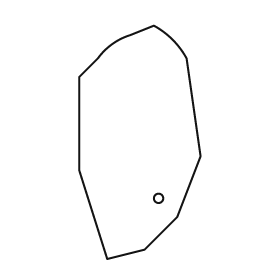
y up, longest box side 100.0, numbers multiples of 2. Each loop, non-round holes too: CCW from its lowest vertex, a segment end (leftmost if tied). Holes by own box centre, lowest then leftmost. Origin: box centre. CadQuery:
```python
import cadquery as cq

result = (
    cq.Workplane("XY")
    .moveTo(-14.0, -50.0)
    .lineTo(2.0, -46.0)
    .lineTo(16.0, -32.0)
    .lineTo(26.0, -6.0)
    .lineTo(20.0, 36.0)
    .threePointArc((14.0, 44.0), (6.0, 50.0))
    .lineTo(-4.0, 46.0)
    .threePointArc((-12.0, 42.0), (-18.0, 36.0))
    .lineTo(-26.0, 28.0)
    .lineTo(-26.0, -12.0)
    .close()
    .moveTo(8.0, -24.0)
    .circle(2.0)
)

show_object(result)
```